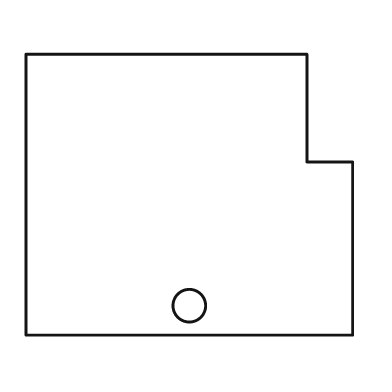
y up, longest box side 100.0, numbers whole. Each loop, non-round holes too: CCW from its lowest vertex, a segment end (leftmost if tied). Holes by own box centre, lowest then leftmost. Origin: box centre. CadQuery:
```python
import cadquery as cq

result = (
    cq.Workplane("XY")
    .moveTo(-50.0, -43.0)
    .lineTo(50.0, -43.0)
    .lineTo(50.0, 10.0)
    .lineTo(36.0, 10.0)
    .lineTo(36.0, 43.0)
    .lineTo(-50.0, 43.0)
    .close()
    .moveTo(0.0, -34.0)
    .circle(5.0)
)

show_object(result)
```